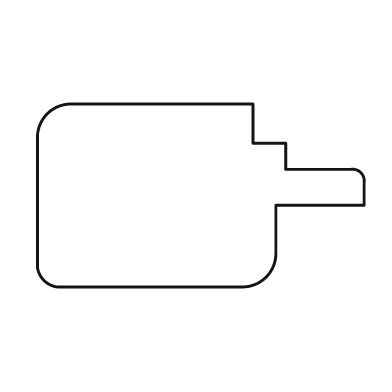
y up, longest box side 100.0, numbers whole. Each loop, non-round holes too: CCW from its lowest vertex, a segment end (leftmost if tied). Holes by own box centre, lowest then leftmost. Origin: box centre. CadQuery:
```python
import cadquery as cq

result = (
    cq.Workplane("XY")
    .moveTo(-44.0, -28.0)
    .lineTo(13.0, -28.0)
    .threePointArc((20.0, -25.0), (23.0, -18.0))
    .lineTo(23.0, -3.0)
    .lineTo(50.0, -3.0)
    .lineTo(50.0, 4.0)
    .threePointArc((49.0, 7.0), (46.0, 8.0))
    .lineTo(26.0, 8.0)
    .lineTo(26.0, 16.0)
    .lineTo(16.0, 16.0)
    .lineTo(16.0, 28.0)
    .lineTo(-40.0, 28.0)
    .threePointArc((-47.0, 25.0), (-50.0, 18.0))
    .lineTo(-50.0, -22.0)
    .threePointArc((-48.0, -26.0), (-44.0, -28.0))
    .close()
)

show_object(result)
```